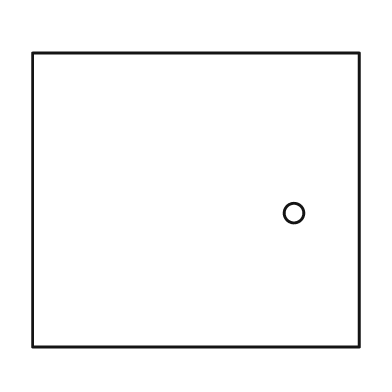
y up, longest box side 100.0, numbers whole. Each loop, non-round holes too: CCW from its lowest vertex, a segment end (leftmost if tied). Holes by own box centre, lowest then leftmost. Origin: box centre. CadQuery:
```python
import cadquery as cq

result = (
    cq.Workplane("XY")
    .moveTo(-50.0, -45.0)
    .lineTo(50.0, -45.0)
    .lineTo(50.0, 45.0)
    .lineTo(-50.0, 45.0)
    .close()
    .moveTo(30.0, -4.0)
    .circle(3.0)
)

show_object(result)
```